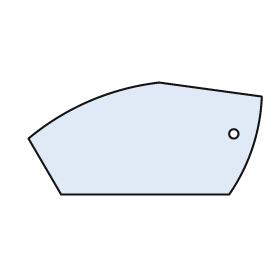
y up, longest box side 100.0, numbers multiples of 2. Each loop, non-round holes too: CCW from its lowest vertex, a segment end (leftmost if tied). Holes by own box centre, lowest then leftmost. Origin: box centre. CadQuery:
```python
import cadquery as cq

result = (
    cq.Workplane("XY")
    .moveTo(-36.0, -24.0)
    .lineTo(36.0, -24.0)
    .threePointArc((46.0, -4.0), (50.0, 18.0))
    .lineTo(6.0, 24.0)
    .threePointArc((-24.0, 16.0), (-50.0, 0.0))
    .close()
    .moveTo(38.0, 2.0)
    .circle(2.0)
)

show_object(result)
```